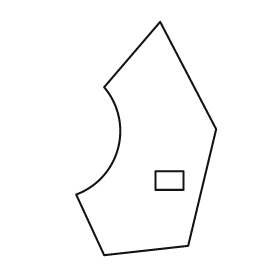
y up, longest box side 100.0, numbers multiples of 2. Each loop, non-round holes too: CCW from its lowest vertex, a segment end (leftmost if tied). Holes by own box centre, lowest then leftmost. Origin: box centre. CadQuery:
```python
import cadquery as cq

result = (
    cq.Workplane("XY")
    .moveTo(-18.0, -50.0)
    .lineTo(18.0, -46.0)
    .lineTo(30.0, 4.0)
    .lineTo(6.0, 50.0)
    .lineTo(-18.0, 22.0)
    .threePointArc((-12.0, -4.0), (-30.0, -24.0))
    .close()
    .moveTo(4.0, -22.0)
    .lineTo(16.0, -22.0)
    .lineTo(16.0, -14.0)
    .lineTo(4.0, -14.0)
    .close()
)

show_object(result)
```